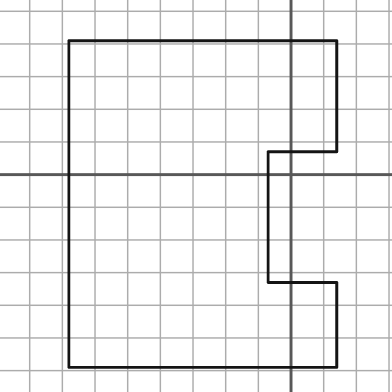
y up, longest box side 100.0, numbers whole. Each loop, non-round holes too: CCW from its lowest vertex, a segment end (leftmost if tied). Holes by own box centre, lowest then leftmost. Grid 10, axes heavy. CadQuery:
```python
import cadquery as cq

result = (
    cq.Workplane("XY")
    .moveTo(-68.0, -59.0)
    .lineTo(14.0, -59.0)
    .lineTo(14.0, -33.0)
    .lineTo(-7.0, -33.0)
    .lineTo(-7.0, 7.0)
    .lineTo(14.0, 7.0)
    .lineTo(14.0, 41.0)
    .lineTo(-68.0, 41.0)
    .close()
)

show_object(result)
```